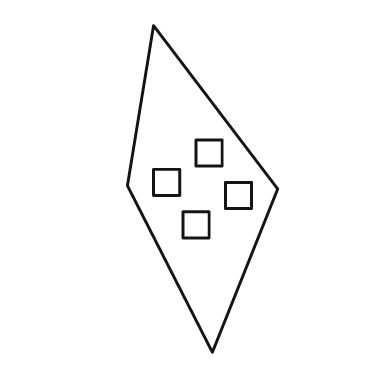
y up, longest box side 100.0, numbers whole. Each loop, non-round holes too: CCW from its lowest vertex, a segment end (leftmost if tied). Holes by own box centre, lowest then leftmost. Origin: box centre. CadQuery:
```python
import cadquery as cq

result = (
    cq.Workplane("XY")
    .moveTo(3.0, -50.0)
    .lineTo(23.0, 0.0)
    .lineTo(-15.0, 50.0)
    .lineTo(-23.0, 1.0)
    .close()
    .moveTo(-6.0, -15.0)
    .lineTo(2.0, -15.0)
    .lineTo(2.0, -7.0)
    .lineTo(-6.0, -7.0)
    .close()
    .moveTo(7.0, -6.0)
    .lineTo(15.0, -6.0)
    .lineTo(15.0, 2.0)
    .lineTo(7.0, 2.0)
    .close()
    .moveTo(-15.0, -2.0)
    .lineTo(-7.0, -2.0)
    .lineTo(-7.0, 6.0)
    .lineTo(-15.0, 6.0)
    .close()
    .moveTo(-2.0, 7.0)
    .lineTo(6.0, 7.0)
    .lineTo(6.0, 15.0)
    .lineTo(-2.0, 15.0)
    .close()
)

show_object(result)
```